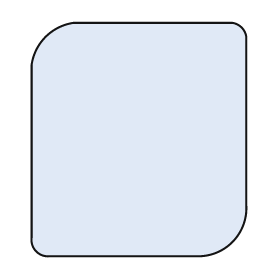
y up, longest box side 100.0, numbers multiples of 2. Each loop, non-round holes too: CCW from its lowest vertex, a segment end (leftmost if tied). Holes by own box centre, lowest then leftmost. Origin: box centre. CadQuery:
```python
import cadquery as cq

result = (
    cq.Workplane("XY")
    .moveTo(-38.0, -50.0)
    .lineTo(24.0, -50.0)
    .threePointArc((40.0, -44.0), (46.0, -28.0))
    .lineTo(46.0, 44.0)
    .threePointArc((44.0, 48.0), (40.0, 50.0))
    .lineTo(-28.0, 50.0)
    .threePointArc((-40.0, 44.0), (-46.0, 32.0))
    .lineTo(-46.0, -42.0)
    .threePointArc((-44.0, -48.0), (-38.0, -50.0))
    .close()
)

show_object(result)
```